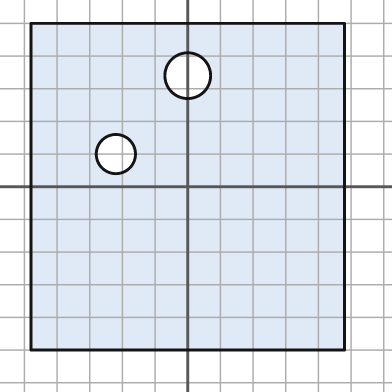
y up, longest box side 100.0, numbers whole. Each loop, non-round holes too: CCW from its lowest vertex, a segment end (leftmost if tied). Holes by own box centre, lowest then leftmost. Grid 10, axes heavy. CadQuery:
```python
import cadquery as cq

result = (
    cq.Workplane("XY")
    .moveTo(-48.0, -50.0)
    .lineTo(48.0, -50.0)
    .lineTo(48.0, 50.0)
    .lineTo(-48.0, 50.0)
    .close()
    .moveTo(-22.0, 10.0)
    .circle(6.0)
    .moveTo(0.0, 34.0)
    .circle(7.0)
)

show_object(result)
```